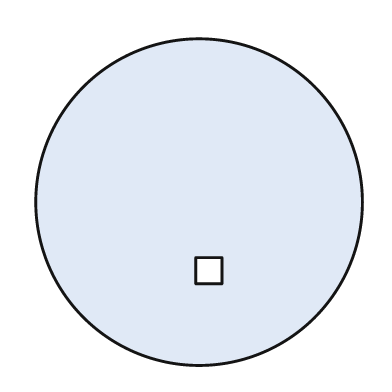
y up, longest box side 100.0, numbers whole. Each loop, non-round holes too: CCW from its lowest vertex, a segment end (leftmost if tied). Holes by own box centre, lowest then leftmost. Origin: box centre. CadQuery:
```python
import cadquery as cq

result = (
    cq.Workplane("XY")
    .moveTo(0.0, 0.0)
    .circle(50.0)
    .moveTo(-1.0, -25.0)
    .lineTo(7.0, -25.0)
    .lineTo(7.0, -17.0)
    .lineTo(-1.0, -17.0)
    .close()
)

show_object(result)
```